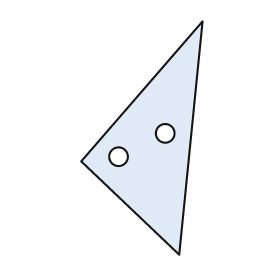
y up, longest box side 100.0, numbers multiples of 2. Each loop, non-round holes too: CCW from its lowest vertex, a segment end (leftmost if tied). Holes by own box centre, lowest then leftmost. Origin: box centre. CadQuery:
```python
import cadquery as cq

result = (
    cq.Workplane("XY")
    .moveTo(16.0, -50.0)
    .lineTo(26.0, 50.0)
    .lineTo(-26.0, -10.0)
    .close()
    .moveTo(-10.0, -8.0)
    .circle(4.0)
    .moveTo(10.0, 2.0)
    .circle(4.0)
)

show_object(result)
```